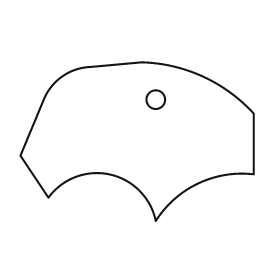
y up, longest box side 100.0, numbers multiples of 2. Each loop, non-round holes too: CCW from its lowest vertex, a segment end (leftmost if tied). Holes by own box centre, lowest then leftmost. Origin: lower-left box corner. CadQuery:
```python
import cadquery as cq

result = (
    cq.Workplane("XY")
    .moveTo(58.0, 0.0)
    .threePointArc((76.0, 16.0), (100.0, 20.0))
    .lineTo(100.0, 46.0)
    .threePointArc((78.0, 62.0), (52.0, 68.0))
    .lineTo(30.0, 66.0)
    .threePointArc((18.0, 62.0), (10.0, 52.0))
    .lineTo(0.0, 28.0)
    .lineTo(12.0, 10.0)
    .threePointArc((38.0, 20.0), (58.0, 0.0))
    .close()
    .moveTo(58.0, 52.0)
    .circle(4.0)
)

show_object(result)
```